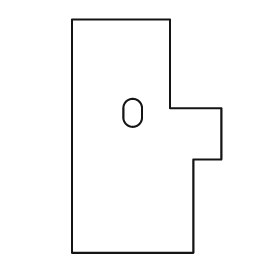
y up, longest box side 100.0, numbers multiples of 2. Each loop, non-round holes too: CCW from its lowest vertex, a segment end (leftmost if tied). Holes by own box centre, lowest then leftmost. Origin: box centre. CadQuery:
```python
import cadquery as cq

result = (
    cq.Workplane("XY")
    .moveTo(-32.0, -50.0)
    .lineTo(20.0, -50.0)
    .lineTo(20.0, -10.0)
    .lineTo(32.0, -10.0)
    .lineTo(32.0, 12.0)
    .lineTo(10.0, 12.0)
    .lineTo(10.0, 50.0)
    .lineTo(-32.0, 50.0)
    .close()
    .moveTo(-10.0, 8.0)
    .threePointArc((-6.0, 4.0), (-2.0, 8.0))
    .lineTo(-2.0, 12.0)
    .threePointArc((-6.0, 16.0), (-10.0, 12.0))
    .close()
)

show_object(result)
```